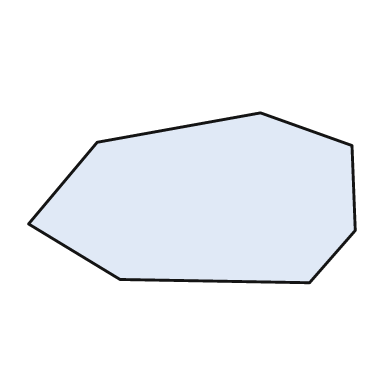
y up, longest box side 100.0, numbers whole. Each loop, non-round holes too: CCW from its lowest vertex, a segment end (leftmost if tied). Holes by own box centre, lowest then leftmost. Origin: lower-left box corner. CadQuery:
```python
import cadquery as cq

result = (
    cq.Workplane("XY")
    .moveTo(86.0, 0.0)
    .lineTo(100.0, 16.0)
    .lineTo(99.0, 42.0)
    .lineTo(71.0, 52.0)
    .lineTo(21.0, 43.0)
    .lineTo(0.0, 18.0)
    .lineTo(28.0, 1.0)
    .close()
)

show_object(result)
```